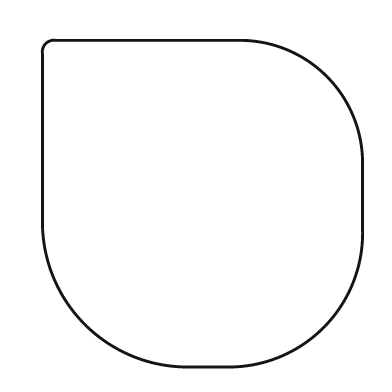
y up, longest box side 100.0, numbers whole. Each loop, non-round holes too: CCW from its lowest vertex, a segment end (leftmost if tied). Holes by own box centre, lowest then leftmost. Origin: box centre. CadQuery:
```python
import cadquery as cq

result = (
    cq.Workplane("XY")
    .moveTo(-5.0, -50.0)
    .lineTo(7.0, -50.0)
    .threePointArc((37.0, -38.0), (49.0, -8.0))
    .lineTo(49.0, 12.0)
    .threePointArc((38.0, 39.0), (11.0, 50.0))
    .lineTo(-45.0, 50.0)
    .threePointArc((-48.0, 49.0), (-49.0, 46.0))
    .lineTo(-49.0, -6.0)
    .threePointArc((-36.0, -37.0), (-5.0, -50.0))
    .close()
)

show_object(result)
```